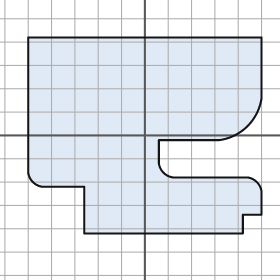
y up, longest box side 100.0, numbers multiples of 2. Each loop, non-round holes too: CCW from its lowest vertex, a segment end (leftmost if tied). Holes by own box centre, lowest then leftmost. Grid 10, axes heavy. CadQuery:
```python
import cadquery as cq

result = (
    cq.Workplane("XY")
    .moveTo(-26.0, -42.0)
    .lineTo(42.0, -42.0)
    .lineTo(42.0, -34.0)
    .lineTo(50.0, -34.0)
    .lineTo(50.0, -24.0)
    .threePointArc((48.0, -20.0), (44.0, -18.0))
    .lineTo(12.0, -18.0)
    .threePointArc((8.0, -16.0), (6.0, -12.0))
    .lineTo(6.0, -2.0)
    .lineTo(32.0, -2.0)
    .threePointArc((44.0, 4.0), (50.0, 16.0))
    .lineTo(50.0, 42.0)
    .lineTo(-50.0, 42.0)
    .lineTo(-50.0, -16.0)
    .threePointArc((-48.0, -20.0), (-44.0, -22.0))
    .lineTo(-26.0, -22.0)
    .close()
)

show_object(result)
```